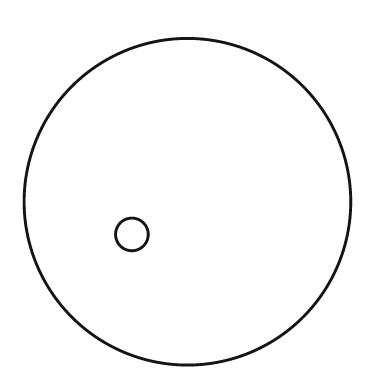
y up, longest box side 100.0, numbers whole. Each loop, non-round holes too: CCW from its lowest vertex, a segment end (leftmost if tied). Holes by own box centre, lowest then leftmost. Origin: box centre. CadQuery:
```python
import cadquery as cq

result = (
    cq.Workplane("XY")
    .moveTo(0.0, 0.0)
    .circle(50.0)
    .moveTo(-17.0, -10.0)
    .circle(5.0)
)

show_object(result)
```